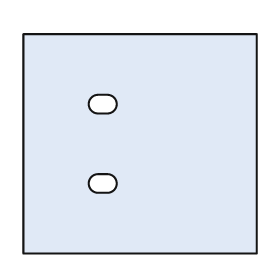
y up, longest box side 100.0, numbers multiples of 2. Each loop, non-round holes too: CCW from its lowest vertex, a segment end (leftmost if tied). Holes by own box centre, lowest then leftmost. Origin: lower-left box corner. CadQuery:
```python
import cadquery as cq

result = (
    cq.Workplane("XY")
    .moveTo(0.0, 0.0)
    .lineTo(100.0, 0.0)
    .lineTo(100.0, 94.0)
    .lineTo(0.0, 94.0)
    .close()
    .moveTo(32.0, 26.0)
    .lineTo(36.0, 26.0)
    .threePointArc((40.0, 30.0), (36.0, 34.0))
    .lineTo(32.0, 34.0)
    .threePointArc((28.0, 30.0), (32.0, 26.0))
    .close()
    .moveTo(32.0, 60.0)
    .lineTo(36.0, 60.0)
    .threePointArc((40.0, 64.0), (36.0, 68.0))
    .lineTo(32.0, 68.0)
    .threePointArc((28.0, 64.0), (32.0, 60.0))
    .close()
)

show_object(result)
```